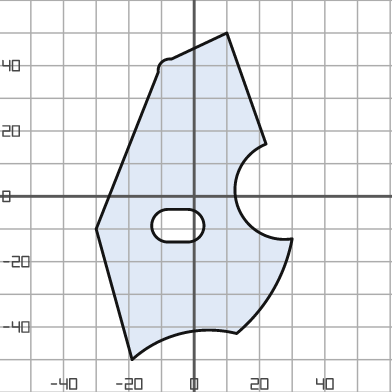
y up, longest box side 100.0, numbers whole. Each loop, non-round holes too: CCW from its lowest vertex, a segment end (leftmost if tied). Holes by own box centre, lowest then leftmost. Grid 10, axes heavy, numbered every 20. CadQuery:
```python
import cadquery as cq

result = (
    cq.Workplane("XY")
    .moveTo(-19.0, -50.0)
    .threePointArc((-4.0, -42.0), (13.0, -42.0))
    .threePointArc((24.0, -29.0), (30.0, -13.0))
    .threePointArc((13.0, -2.0), (22.0, 16.0))
    .lineTo(10.0, 50.0)
    .lineTo(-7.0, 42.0)
    .threePointArc((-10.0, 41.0), (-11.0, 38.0))
    .lineTo(-30.0, -10.0)
    .close()
    .moveTo(-8.0, -14.0)
    .lineTo(-2.0, -14.0)
    .threePointArc((3.0, -9.0), (-2.0, -4.0))
    .lineTo(-8.0, -4.0)
    .threePointArc((-13.0, -9.0), (-8.0, -14.0))
    .close()
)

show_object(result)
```